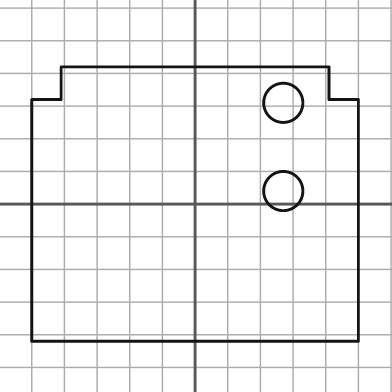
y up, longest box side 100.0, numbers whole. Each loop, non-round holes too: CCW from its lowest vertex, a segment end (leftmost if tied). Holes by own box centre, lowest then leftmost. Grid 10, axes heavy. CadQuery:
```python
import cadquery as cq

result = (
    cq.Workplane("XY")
    .moveTo(-50.0, -42.0)
    .lineTo(50.0, -42.0)
    .lineTo(50.0, 32.0)
    .lineTo(41.0, 32.0)
    .lineTo(41.0, 42.0)
    .lineTo(-41.0, 42.0)
    .lineTo(-41.0, 32.0)
    .lineTo(-50.0, 32.0)
    .close()
    .moveTo(27.0, 4.0)
    .circle(6.0)
    .moveTo(27.0, 31.0)
    .circle(6.0)
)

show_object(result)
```